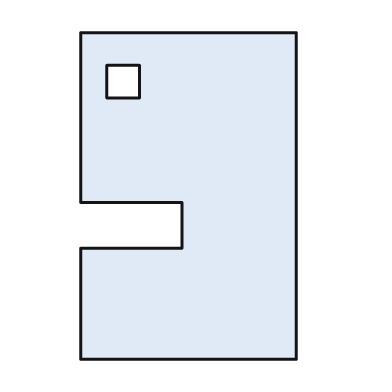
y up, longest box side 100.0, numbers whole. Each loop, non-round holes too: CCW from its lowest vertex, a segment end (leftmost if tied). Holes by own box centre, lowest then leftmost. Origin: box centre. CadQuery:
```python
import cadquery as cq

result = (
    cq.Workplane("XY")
    .moveTo(-33.0, -50.0)
    .lineTo(33.0, -50.0)
    .lineTo(33.0, 50.0)
    .lineTo(-33.0, 50.0)
    .lineTo(-33.0, -2.0)
    .lineTo(-2.0, -2.0)
    .lineTo(-2.0, -16.0)
    .lineTo(-33.0, -16.0)
    .close()
    .moveTo(-25.0, 30.0)
    .lineTo(-15.0, 30.0)
    .lineTo(-15.0, 40.0)
    .lineTo(-25.0, 40.0)
    .close()
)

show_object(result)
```